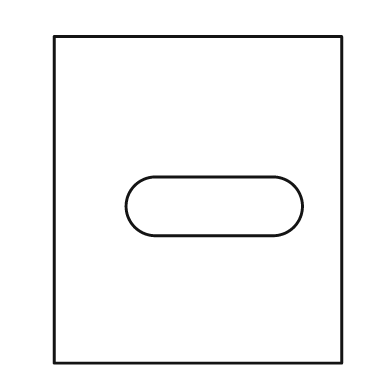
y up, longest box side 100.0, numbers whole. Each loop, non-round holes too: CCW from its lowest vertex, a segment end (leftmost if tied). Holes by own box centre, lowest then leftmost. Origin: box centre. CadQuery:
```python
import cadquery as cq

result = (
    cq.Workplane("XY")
    .moveTo(-44.0, -50.0)
    .lineTo(44.0, -50.0)
    .lineTo(44.0, 50.0)
    .lineTo(-44.0, 50.0)
    .close()
    .moveTo(-13.0, -11.0)
    .lineTo(23.0, -11.0)
    .threePointArc((32.0, -2.0), (23.0, 7.0))
    .lineTo(-13.0, 7.0)
    .threePointArc((-22.0, -2.0), (-13.0, -11.0))
    .close()
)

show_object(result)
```